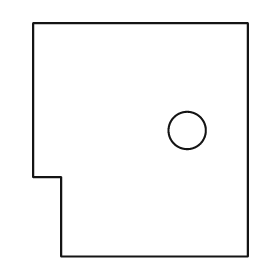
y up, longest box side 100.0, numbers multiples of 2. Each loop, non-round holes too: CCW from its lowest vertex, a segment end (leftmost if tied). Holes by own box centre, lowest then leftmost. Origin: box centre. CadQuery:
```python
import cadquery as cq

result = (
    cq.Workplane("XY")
    .moveTo(-34.0, -50.0)
    .lineTo(46.0, -50.0)
    .lineTo(46.0, 50.0)
    .lineTo(-46.0, 50.0)
    .lineTo(-46.0, -16.0)
    .lineTo(-34.0, -16.0)
    .close()
    .moveTo(20.0, 4.0)
    .circle(8.0)
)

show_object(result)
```